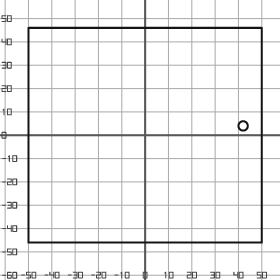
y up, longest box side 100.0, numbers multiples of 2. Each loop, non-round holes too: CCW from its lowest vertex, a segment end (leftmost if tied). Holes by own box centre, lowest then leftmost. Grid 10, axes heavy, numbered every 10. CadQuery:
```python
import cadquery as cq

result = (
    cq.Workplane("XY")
    .moveTo(-50.0, -46.0)
    .lineTo(50.0, -46.0)
    .lineTo(50.0, 46.0)
    .lineTo(-50.0, 46.0)
    .close()
    .moveTo(42.0, 4.0)
    .circle(2.0)
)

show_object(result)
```